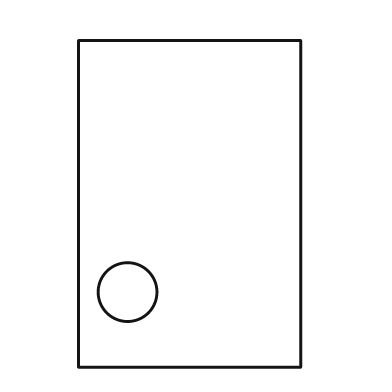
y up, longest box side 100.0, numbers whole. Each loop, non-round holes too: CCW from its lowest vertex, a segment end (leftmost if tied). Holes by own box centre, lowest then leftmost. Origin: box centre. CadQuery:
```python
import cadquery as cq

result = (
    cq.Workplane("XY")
    .moveTo(-34.0, -50.0)
    .lineTo(34.0, -50.0)
    .lineTo(34.0, 50.0)
    .lineTo(-34.0, 50.0)
    .close()
    .moveTo(-19.0, -27.0)
    .circle(9.0)
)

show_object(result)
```